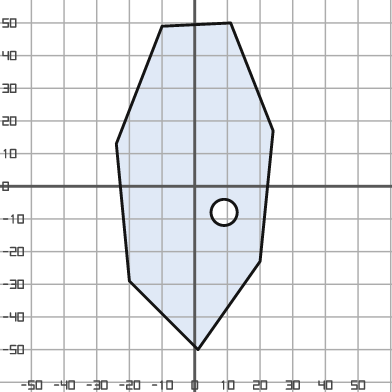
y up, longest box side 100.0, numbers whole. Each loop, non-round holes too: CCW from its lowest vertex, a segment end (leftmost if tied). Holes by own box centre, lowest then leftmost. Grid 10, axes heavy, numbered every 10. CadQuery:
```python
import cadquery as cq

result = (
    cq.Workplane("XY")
    .moveTo(1.0, -50.0)
    .lineTo(20.0, -23.0)
    .lineTo(24.0, 17.0)
    .lineTo(11.0, 50.0)
    .lineTo(-10.0, 49.0)
    .lineTo(-24.0, 13.0)
    .lineTo(-20.0, -29.0)
    .close()
    .moveTo(9.0, -8.0)
    .circle(4.0)
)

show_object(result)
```